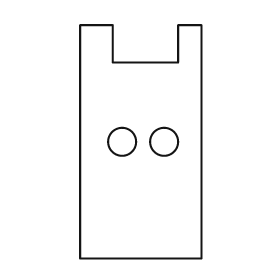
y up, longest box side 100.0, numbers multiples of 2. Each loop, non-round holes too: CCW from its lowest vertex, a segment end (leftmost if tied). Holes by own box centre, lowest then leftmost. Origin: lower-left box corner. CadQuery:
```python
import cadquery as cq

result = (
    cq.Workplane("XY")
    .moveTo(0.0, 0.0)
    .lineTo(52.0, 0.0)
    .lineTo(52.0, 100.0)
    .lineTo(42.0, 100.0)
    .lineTo(42.0, 84.0)
    .lineTo(14.0, 84.0)
    .lineTo(14.0, 100.0)
    .lineTo(0.0, 100.0)
    .close()
    .moveTo(18.0, 50.0)
    .circle(6.0)
    .moveTo(36.0, 50.0)
    .circle(6.0)
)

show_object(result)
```